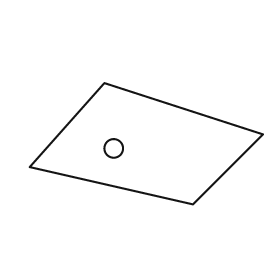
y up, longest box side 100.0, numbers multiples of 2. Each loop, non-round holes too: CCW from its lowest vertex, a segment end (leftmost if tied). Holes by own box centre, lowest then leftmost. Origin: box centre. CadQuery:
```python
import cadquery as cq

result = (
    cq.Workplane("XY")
    .moveTo(20.0, -26.0)
    .lineTo(50.0, 4.0)
    .lineTo(-18.0, 26.0)
    .lineTo(-50.0, -10.0)
    .close()
    .moveTo(-14.0, -2.0)
    .circle(4.0)
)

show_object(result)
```